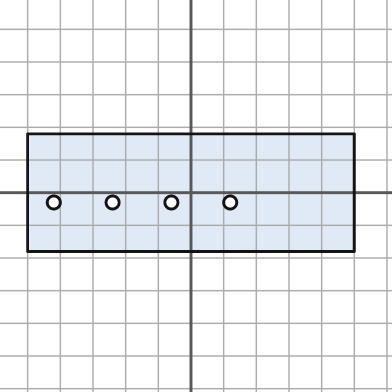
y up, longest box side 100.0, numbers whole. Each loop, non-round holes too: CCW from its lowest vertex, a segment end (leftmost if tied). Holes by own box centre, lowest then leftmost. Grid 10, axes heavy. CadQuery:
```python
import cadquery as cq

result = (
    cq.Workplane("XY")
    .moveTo(-50.0, -18.0)
    .lineTo(50.0, -18.0)
    .lineTo(50.0, 18.0)
    .lineTo(-50.0, 18.0)
    .close()
    .moveTo(-42.0, -3.0)
    .circle(2.0)
    .moveTo(-24.0, -3.0)
    .circle(2.0)
    .moveTo(-6.0, -3.0)
    .circle(2.0)
    .moveTo(12.0, -3.0)
    .circle(2.0)
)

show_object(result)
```